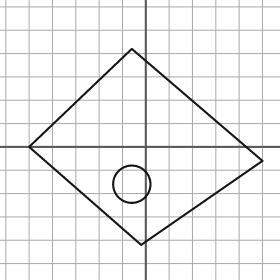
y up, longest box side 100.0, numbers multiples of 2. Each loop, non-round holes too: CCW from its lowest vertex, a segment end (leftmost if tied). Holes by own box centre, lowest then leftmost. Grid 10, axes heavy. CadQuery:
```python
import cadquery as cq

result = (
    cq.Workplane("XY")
    .moveTo(-2.0, -42.0)
    .lineTo(50.0, -6.0)
    .lineTo(-6.0, 42.0)
    .lineTo(-50.0, 0.0)
    .close()
    .moveTo(-6.0, -16.0)
    .circle(8.0)
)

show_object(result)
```